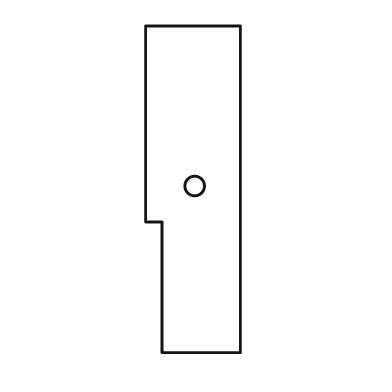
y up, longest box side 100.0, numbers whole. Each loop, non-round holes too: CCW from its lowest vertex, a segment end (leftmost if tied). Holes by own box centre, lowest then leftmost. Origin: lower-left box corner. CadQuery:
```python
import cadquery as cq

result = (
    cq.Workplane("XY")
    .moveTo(5.0, 0.0)
    .lineTo(29.0, 0.0)
    .lineTo(29.0, 100.0)
    .lineTo(0.0, 100.0)
    .lineTo(0.0, 40.0)
    .lineTo(5.0, 40.0)
    .close()
    .moveTo(15.0, 51.0)
    .circle(3.0)
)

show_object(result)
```